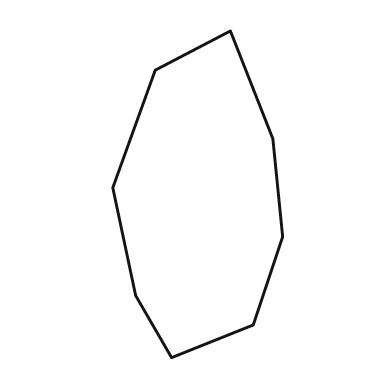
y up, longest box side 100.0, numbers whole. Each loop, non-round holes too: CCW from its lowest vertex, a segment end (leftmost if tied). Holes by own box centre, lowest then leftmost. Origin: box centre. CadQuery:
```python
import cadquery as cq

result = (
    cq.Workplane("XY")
    .moveTo(-8.0, -50.0)
    .lineTo(17.0, -40.0)
    .lineTo(26.0, -13.0)
    .lineTo(23.0, 17.0)
    .lineTo(10.0, 50.0)
    .lineTo(-13.0, 38.0)
    .lineTo(-26.0, 2.0)
    .lineTo(-19.0, -31.0)
    .close()
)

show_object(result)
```